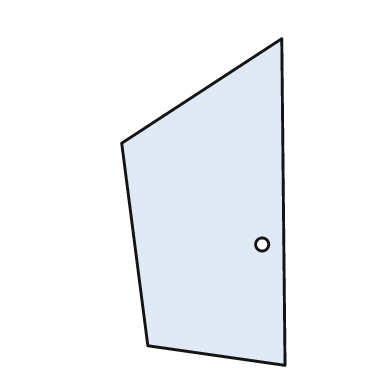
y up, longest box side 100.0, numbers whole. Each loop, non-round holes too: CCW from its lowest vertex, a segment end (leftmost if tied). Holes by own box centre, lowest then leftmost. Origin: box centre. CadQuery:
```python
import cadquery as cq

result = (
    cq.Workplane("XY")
    .moveTo(25.0, -50.0)
    .lineTo(24.0, 50.0)
    .lineTo(-25.0, 18.0)
    .lineTo(-17.0, -44.0)
    .close()
    .moveTo(18.0, -13.0)
    .circle(2.0)
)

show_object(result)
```